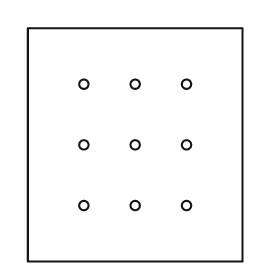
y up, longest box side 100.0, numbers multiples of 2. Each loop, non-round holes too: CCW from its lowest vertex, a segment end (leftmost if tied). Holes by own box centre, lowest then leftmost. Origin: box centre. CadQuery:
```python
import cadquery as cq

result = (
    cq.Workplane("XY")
    .moveTo(-46.0, -50.0)
    .lineTo(46.0, -50.0)
    .lineTo(46.0, 50.0)
    .lineTo(-46.0, 50.0)
    .close()
    .moveTo(-22.0, -26.0)
    .circle(2.0)
    .moveTo(0.0, -26.0)
    .circle(2.0)
    .moveTo(22.0, -26.0)
    .circle(2.0)
    .moveTo(-22.0, 0.0)
    .circle(2.0)
    .moveTo(0.0, 0.0)
    .circle(2.0)
    .moveTo(22.0, 0.0)
    .circle(2.0)
    .moveTo(-22.0, 26.0)
    .circle(2.0)
    .moveTo(0.0, 26.0)
    .circle(2.0)
    .moveTo(22.0, 26.0)
    .circle(2.0)
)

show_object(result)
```